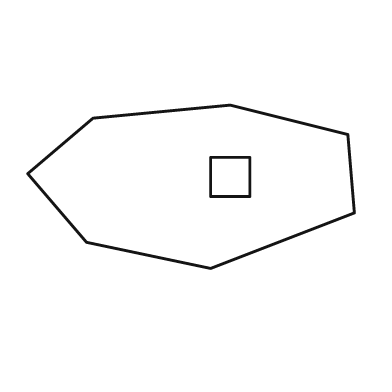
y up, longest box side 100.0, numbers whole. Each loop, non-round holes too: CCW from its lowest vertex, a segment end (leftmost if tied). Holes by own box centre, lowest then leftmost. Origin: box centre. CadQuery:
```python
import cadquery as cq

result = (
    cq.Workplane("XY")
    .moveTo(6.0, -25.0)
    .lineTo(50.0, -8.0)
    .lineTo(48.0, 16.0)
    .lineTo(12.0, 25.0)
    .lineTo(-30.0, 21.0)
    .lineTo(-50.0, 4.0)
    .lineTo(-32.0, -17.0)
    .close()
    .moveTo(6.0, -3.0)
    .lineTo(18.0, -3.0)
    .lineTo(18.0, 9.0)
    .lineTo(6.0, 9.0)
    .close()
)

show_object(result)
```